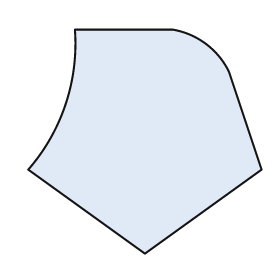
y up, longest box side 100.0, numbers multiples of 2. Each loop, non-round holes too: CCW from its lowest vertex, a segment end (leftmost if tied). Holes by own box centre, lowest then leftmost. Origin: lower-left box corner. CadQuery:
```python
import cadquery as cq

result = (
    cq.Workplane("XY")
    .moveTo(50.0, 0.0)
    .lineTo(100.0, 36.0)
    .lineTo(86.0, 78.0)
    .threePointArc((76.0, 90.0), (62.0, 96.0))
    .lineTo(20.0, 96.0)
    .threePointArc((16.0, 64.0), (0.0, 36.0))
    .close()
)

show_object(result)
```